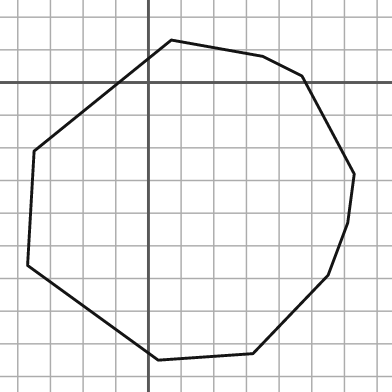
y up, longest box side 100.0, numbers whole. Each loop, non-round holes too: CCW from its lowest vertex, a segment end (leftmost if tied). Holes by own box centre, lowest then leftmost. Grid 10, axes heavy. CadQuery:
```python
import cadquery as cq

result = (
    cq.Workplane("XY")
    .moveTo(3.0, -85.0)
    .lineTo(32.0, -83.0)
    .lineTo(55.0, -59.0)
    .lineTo(61.0, -43.0)
    .lineTo(63.0, -28.0)
    .lineTo(47.0, 2.0)
    .lineTo(35.0, 8.0)
    .lineTo(7.0, 13.0)
    .lineTo(-35.0, -21.0)
    .lineTo(-37.0, -56.0)
    .close()
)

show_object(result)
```